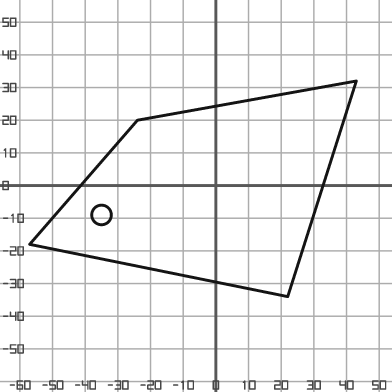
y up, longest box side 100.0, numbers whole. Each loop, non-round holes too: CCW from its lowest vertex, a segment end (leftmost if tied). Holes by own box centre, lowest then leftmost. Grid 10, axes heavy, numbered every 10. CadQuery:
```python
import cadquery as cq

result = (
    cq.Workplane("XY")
    .moveTo(22.0, -34.0)
    .lineTo(43.0, 32.0)
    .lineTo(-24.0, 20.0)
    .lineTo(-57.0, -18.0)
    .close()
    .moveTo(-35.0, -9.0)
    .circle(3.0)
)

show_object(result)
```